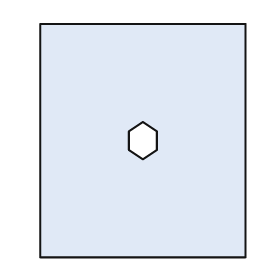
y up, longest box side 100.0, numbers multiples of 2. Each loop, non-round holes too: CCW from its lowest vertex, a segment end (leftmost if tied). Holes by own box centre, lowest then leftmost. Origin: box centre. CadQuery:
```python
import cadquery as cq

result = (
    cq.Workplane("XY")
    .moveTo(-44.0, -50.0)
    .lineTo(44.0, -50.0)
    .lineTo(44.0, 50.0)
    .lineTo(-44.0, 50.0)
    .close()
    .moveTo(0.0, -8.0)
    .lineTo(6.0, -4.0)
    .lineTo(6.0, 4.0)
    .lineTo(0.0, 8.0)
    .lineTo(-6.0, 4.0)
    .lineTo(-6.0, -4.0)
    .close()
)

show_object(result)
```